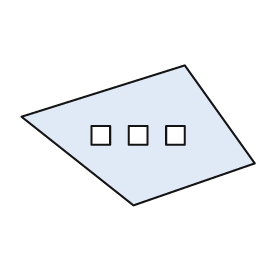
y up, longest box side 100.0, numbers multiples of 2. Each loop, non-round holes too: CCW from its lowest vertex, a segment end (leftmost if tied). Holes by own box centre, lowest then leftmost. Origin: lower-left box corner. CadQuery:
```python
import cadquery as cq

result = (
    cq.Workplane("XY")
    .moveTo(48.0, 0.0)
    .lineTo(100.0, 18.0)
    .lineTo(70.0, 60.0)
    .lineTo(0.0, 38.0)
    .close()
    .moveTo(30.0, 26.0)
    .lineTo(38.0, 26.0)
    .lineTo(38.0, 34.0)
    .lineTo(30.0, 34.0)
    .close()
    .moveTo(46.0, 26.0)
    .lineTo(54.0, 26.0)
    .lineTo(54.0, 34.0)
    .lineTo(46.0, 34.0)
    .close()
    .moveTo(62.0, 26.0)
    .lineTo(70.0, 26.0)
    .lineTo(70.0, 34.0)
    .lineTo(62.0, 34.0)
    .close()
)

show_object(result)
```